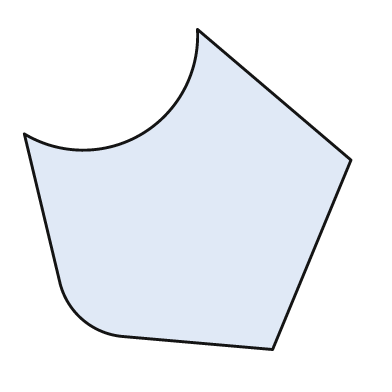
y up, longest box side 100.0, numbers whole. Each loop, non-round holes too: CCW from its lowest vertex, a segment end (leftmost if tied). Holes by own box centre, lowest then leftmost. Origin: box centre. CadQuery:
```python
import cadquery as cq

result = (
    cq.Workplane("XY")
    .moveTo(26.0, -49.0)
    .lineTo(50.0, 9.0)
    .lineTo(3.0, 49.0)
    .threePointArc((-14.0, 17.0), (-50.0, 17.0))
    .lineTo(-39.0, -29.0)
    .threePointArc((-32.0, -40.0), (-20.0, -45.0))
    .close()
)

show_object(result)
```